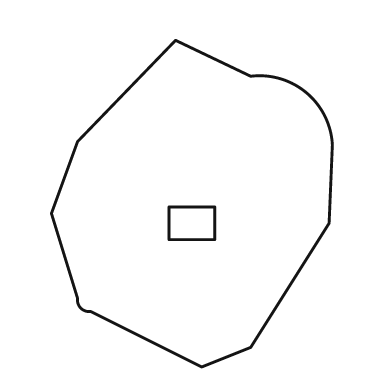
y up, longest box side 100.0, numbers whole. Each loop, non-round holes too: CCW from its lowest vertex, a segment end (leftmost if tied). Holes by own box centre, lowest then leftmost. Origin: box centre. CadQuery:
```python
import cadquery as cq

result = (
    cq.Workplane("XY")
    .moveTo(3.0, -50.0)
    .lineTo(18.0, -44.0)
    .lineTo(42.0, -6.0)
    .lineTo(43.0, 18.0)
    .threePointArc((35.0, 34.0), (18.0, 39.0))
    .lineTo(-5.0, 50.0)
    .lineTo(-35.0, 19.0)
    .lineTo(-43.0, -3.0)
    .lineTo(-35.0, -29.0)
    .threePointArc((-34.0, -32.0), (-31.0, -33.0))
    .close()
    .moveTo(-7.0, -11.0)
    .lineTo(7.0, -11.0)
    .lineTo(7.0, -1.0)
    .lineTo(-7.0, -1.0)
    .close()
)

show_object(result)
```